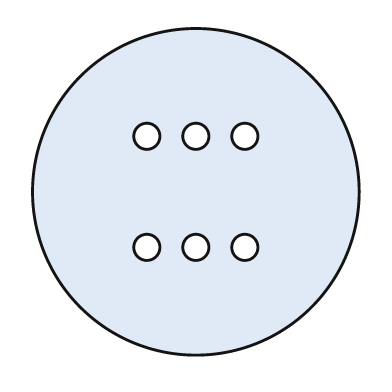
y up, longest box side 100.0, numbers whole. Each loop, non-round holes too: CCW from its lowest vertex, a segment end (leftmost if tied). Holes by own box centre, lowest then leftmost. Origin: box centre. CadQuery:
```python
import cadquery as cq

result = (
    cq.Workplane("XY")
    .moveTo(0.0, 0.0)
    .circle(50.0)
    .moveTo(-15.0, -17.0)
    .circle(4.0)
    .moveTo(0.0, -17.0)
    .circle(4.0)
    .moveTo(15.0, -17.0)
    .circle(4.0)
    .moveTo(-15.0, 17.0)
    .circle(4.0)
    .moveTo(0.0, 17.0)
    .circle(4.0)
    .moveTo(15.0, 17.0)
    .circle(4.0)
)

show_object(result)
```